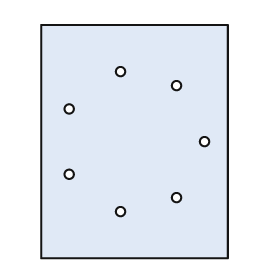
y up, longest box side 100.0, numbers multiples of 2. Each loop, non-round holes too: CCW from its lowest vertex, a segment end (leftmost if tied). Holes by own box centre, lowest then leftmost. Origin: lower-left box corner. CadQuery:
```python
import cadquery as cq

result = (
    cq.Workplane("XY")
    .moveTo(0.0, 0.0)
    .lineTo(80.0, 0.0)
    .lineTo(80.0, 100.0)
    .lineTo(0.0, 100.0)
    .close()
    .moveTo(34.0, 20.0)
    .circle(2.0)
    .moveTo(58.0, 26.0)
    .circle(2.0)
    .moveTo(12.0, 36.0)
    .circle(2.0)
    .moveTo(70.0, 50.0)
    .circle(2.0)
    .moveTo(12.0, 64.0)
    .circle(2.0)
    .moveTo(58.0, 74.0)
    .circle(2.0)
    .moveTo(34.0, 80.0)
    .circle(2.0)
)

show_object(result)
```